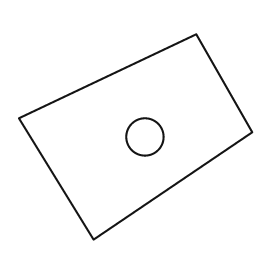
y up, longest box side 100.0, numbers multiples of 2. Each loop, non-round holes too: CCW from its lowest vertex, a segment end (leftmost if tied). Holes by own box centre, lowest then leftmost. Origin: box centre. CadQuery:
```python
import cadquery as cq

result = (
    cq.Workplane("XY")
    .moveTo(-18.0, -44.0)
    .lineTo(50.0, 2.0)
    .lineTo(26.0, 44.0)
    .lineTo(-50.0, 8.0)
    .close()
    .moveTo(4.0, 0.0)
    .circle(8.0)
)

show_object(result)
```